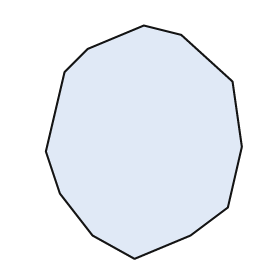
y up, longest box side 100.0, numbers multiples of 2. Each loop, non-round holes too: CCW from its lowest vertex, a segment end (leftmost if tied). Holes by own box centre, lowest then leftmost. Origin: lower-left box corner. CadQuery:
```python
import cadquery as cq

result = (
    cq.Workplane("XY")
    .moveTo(38.0, 0.0)
    .lineTo(62.0, 10.0)
    .lineTo(78.0, 22.0)
    .lineTo(84.0, 48.0)
    .lineTo(80.0, 76.0)
    .lineTo(58.0, 96.0)
    .lineTo(42.0, 100.0)
    .lineTo(18.0, 90.0)
    .lineTo(8.0, 80.0)
    .lineTo(0.0, 46.0)
    .lineTo(6.0, 28.0)
    .lineTo(20.0, 10.0)
    .close()
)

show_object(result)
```